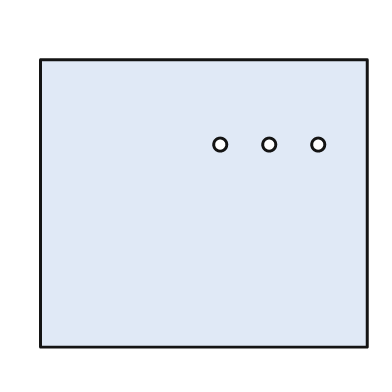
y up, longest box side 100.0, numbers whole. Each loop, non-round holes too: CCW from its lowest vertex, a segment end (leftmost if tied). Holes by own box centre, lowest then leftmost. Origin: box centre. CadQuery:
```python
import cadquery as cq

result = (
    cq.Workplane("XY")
    .moveTo(-50.0, -44.0)
    .lineTo(50.0, -44.0)
    .lineTo(50.0, 44.0)
    .lineTo(-50.0, 44.0)
    .close()
    .moveTo(5.0, 18.0)
    .circle(2.0)
    .moveTo(20.0, 18.0)
    .circle(2.0)
    .moveTo(35.0, 18.0)
    .circle(2.0)
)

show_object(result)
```